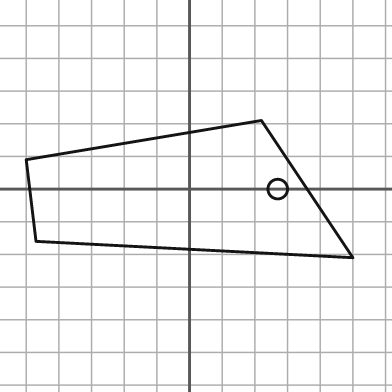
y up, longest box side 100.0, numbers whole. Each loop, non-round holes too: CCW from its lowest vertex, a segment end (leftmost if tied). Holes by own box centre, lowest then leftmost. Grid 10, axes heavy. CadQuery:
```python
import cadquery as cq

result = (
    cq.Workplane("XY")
    .moveTo(50.0, -21.0)
    .lineTo(22.0, 21.0)
    .lineTo(-50.0, 9.0)
    .lineTo(-47.0, -16.0)
    .close()
    .moveTo(27.0, 0.0)
    .circle(3.0)
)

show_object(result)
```